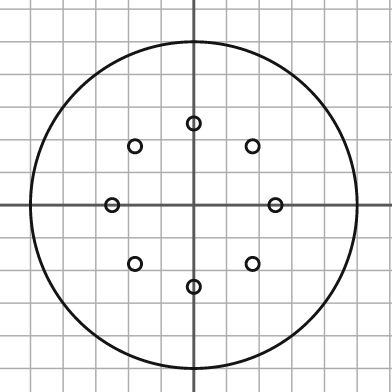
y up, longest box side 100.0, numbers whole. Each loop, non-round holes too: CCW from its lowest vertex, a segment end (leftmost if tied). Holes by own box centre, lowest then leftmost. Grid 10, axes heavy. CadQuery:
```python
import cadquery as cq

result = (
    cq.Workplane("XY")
    .moveTo(0.0, 0.0)
    .circle(50.0)
    .moveTo(0.0, -25.0)
    .circle(2.0)
    .moveTo(-18.0, -18.0)
    .circle(2.0)
    .moveTo(18.0, -18.0)
    .circle(2.0)
    .moveTo(-25.0, 0.0)
    .circle(2.0)
    .moveTo(25.0, 0.0)
    .circle(2.0)
    .moveTo(-18.0, 18.0)
    .circle(2.0)
    .moveTo(18.0, 18.0)
    .circle(2.0)
    .moveTo(0.0, 25.0)
    .circle(2.0)
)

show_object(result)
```